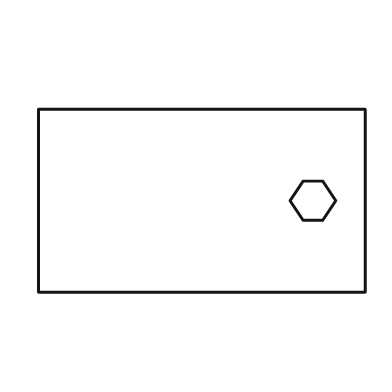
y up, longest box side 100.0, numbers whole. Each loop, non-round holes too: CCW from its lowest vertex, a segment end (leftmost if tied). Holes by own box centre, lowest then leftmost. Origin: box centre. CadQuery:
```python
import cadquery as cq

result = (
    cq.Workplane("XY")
    .moveTo(-50.0, -28.0)
    .lineTo(50.0, -28.0)
    .lineTo(50.0, 28.0)
    .lineTo(-50.0, 28.0)
    .close()
    .moveTo(31.0, -6.0)
    .lineTo(37.0, -6.0)
    .lineTo(41.0, 0.0)
    .lineTo(37.0, 6.0)
    .lineTo(31.0, 6.0)
    .lineTo(27.0, 0.0)
    .close()
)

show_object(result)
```